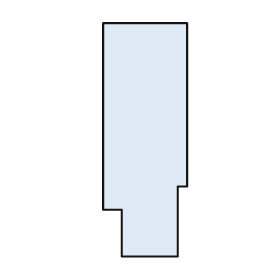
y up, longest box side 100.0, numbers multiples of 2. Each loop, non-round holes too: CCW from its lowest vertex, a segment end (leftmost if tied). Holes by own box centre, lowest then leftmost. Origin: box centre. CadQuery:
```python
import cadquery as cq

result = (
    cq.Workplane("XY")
    .moveTo(-10.0, -50.0)
    .lineTo(14.0, -50.0)
    .lineTo(14.0, -20.0)
    .lineTo(18.0, -20.0)
    .lineTo(18.0, 50.0)
    .lineTo(-18.0, 50.0)
    .lineTo(-18.0, -30.0)
    .lineTo(-10.0, -30.0)
    .close()
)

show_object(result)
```